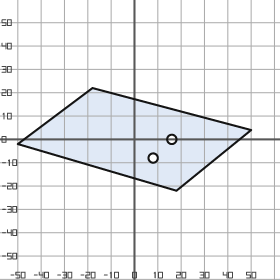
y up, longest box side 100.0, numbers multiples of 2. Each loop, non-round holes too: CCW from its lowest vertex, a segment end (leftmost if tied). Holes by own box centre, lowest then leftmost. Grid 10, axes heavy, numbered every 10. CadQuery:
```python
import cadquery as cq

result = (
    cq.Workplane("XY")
    .moveTo(18.0, -22.0)
    .lineTo(50.0, 4.0)
    .lineTo(-18.0, 22.0)
    .lineTo(-50.0, -2.0)
    .close()
    .moveTo(8.0, -8.0)
    .circle(2.0)
    .moveTo(16.0, 0.0)
    .circle(2.0)
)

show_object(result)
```